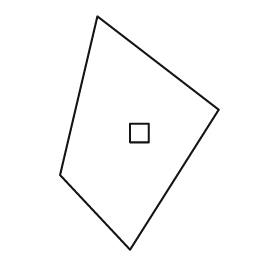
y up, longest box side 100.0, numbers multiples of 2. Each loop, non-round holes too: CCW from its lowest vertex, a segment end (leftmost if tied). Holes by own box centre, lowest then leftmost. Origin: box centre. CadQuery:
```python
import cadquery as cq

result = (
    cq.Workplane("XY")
    .moveTo(-4.0, -50.0)
    .lineTo(34.0, 10.0)
    .lineTo(-18.0, 50.0)
    .lineTo(-34.0, -18.0)
    .close()
    .moveTo(-4.0, -4.0)
    .lineTo(4.0, -4.0)
    .lineTo(4.0, 4.0)
    .lineTo(-4.0, 4.0)
    .close()
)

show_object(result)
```